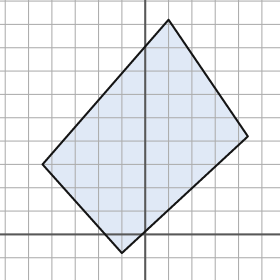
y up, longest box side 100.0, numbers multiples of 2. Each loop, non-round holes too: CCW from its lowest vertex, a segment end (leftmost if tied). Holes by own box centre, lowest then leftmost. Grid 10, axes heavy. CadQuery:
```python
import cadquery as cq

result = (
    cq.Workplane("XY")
    .moveTo(-10.0, -8.0)
    .lineTo(44.0, 42.0)
    .lineTo(10.0, 92.0)
    .lineTo(-44.0, 30.0)
    .close()
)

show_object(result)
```